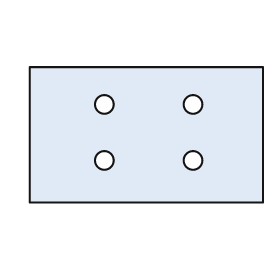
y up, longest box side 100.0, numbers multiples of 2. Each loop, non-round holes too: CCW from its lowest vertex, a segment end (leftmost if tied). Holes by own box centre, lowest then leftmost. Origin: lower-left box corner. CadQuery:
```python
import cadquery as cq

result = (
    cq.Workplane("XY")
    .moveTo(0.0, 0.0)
    .lineTo(100.0, 0.0)
    .lineTo(100.0, 58.0)
    .lineTo(0.0, 58.0)
    .close()
    .moveTo(32.0, 18.0)
    .circle(4.0)
    .moveTo(70.0, 18.0)
    .circle(4.0)
    .moveTo(32.0, 42.0)
    .circle(4.0)
    .moveTo(70.0, 42.0)
    .circle(4.0)
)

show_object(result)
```